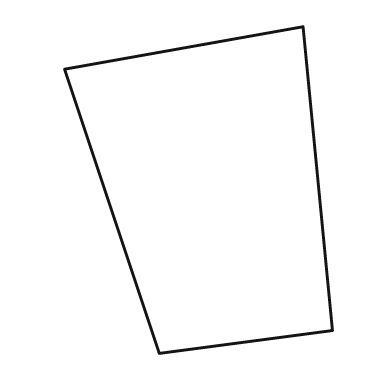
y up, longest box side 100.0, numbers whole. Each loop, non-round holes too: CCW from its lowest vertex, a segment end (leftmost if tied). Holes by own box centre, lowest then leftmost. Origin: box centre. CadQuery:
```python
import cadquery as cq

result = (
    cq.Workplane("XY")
    .moveTo(-12.0, -50.0)
    .lineTo(41.0, -43.0)
    .lineTo(32.0, 50.0)
    .lineTo(-41.0, 37.0)
    .close()
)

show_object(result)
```